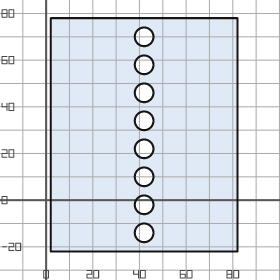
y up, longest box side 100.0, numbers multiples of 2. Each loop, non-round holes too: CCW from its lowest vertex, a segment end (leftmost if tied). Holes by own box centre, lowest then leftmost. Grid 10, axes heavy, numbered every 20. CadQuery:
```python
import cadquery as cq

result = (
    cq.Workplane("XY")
    .moveTo(2.0, -22.0)
    .lineTo(82.0, -22.0)
    .lineTo(82.0, 78.0)
    .lineTo(2.0, 78.0)
    .close()
    .moveTo(42.0, -14.0)
    .circle(4.0)
    .moveTo(42.0, -2.0)
    .circle(4.0)
    .moveTo(42.0, 10.0)
    .circle(4.0)
    .moveTo(42.0, 22.0)
    .circle(4.0)
    .moveTo(42.0, 34.0)
    .circle(4.0)
    .moveTo(42.0, 46.0)
    .circle(4.0)
    .moveTo(42.0, 58.0)
    .circle(4.0)
    .moveTo(42.0, 70.0)
    .circle(4.0)
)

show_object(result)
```